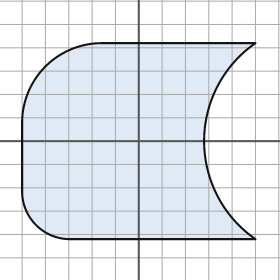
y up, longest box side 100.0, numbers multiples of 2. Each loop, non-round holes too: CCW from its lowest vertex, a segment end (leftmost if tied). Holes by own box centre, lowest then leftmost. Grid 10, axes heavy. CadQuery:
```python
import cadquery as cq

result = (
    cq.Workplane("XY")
    .moveTo(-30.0, -42.0)
    .lineTo(50.0, -42.0)
    .threePointArc((28.0, 0.0), (50.0, 42.0))
    .lineTo(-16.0, 42.0)
    .threePointArc((-40.0, 32.0), (-50.0, 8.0))
    .lineTo(-50.0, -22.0)
    .threePointArc((-44.0, -36.0), (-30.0, -42.0))
    .close()
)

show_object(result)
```